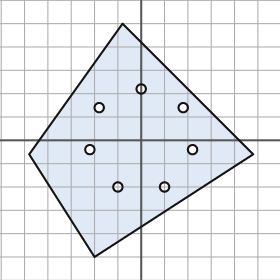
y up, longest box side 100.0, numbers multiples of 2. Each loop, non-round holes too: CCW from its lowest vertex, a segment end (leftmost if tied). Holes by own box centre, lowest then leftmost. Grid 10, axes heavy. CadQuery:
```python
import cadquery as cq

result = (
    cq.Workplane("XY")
    .moveTo(-20.0, -50.0)
    .lineTo(48.0, -6.0)
    .lineTo(-8.0, 50.0)
    .lineTo(-48.0, -6.0)
    .close()
    .moveTo(-10.0, -20.0)
    .circle(2.0)
    .moveTo(10.0, -20.0)
    .circle(2.0)
    .moveTo(-22.0, -4.0)
    .circle(2.0)
    .moveTo(22.0, -4.0)
    .circle(2.0)
    .moveTo(-18.0, 14.0)
    .circle(2.0)
    .moveTo(18.0, 14.0)
    .circle(2.0)
    .moveTo(0.0, 22.0)
    .circle(2.0)
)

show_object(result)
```